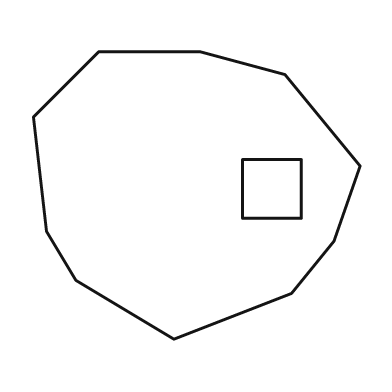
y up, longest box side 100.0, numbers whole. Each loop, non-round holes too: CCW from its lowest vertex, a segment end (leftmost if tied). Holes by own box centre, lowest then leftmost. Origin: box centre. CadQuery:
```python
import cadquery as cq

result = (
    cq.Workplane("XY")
    .moveTo(-7.0, -44.0)
    .lineTo(29.0, -30.0)
    .lineTo(42.0, -14.0)
    .lineTo(50.0, 9.0)
    .lineTo(27.0, 37.0)
    .lineTo(1.0, 44.0)
    .lineTo(-30.0, 44.0)
    .lineTo(-50.0, 24.0)
    .lineTo(-46.0, -11.0)
    .lineTo(-37.0, -26.0)
    .close()
    .moveTo(14.0, -7.0)
    .lineTo(32.0, -7.0)
    .lineTo(32.0, 11.0)
    .lineTo(14.0, 11.0)
    .close()
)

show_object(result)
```